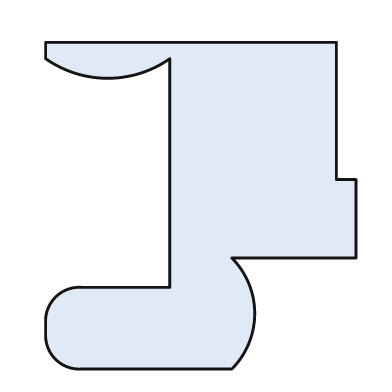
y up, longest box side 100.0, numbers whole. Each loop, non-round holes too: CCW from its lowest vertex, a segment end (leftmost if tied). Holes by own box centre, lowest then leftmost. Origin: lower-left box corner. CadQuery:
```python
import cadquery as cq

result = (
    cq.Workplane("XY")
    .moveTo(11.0, 0.0)
    .lineTo(57.0, 0.0)
    .threePointArc((64.0, 17.0), (57.0, 34.0))
    .lineTo(95.0, 34.0)
    .lineTo(95.0, 58.0)
    .lineTo(89.0, 58.0)
    .lineTo(89.0, 100.0)
    .lineTo(0.0, 100.0)
    .lineTo(0.0, 95.0)
    .threePointArc((19.0, 89.0), (38.0, 95.0))
    .lineTo(38.0, 25.0)
    .lineTo(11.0, 25.0)
    .threePointArc((3.0, 22.0), (0.0, 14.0))
    .lineTo(0.0, 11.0)
    .threePointArc((3.0, 3.0), (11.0, 0.0))
    .close()
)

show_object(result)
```